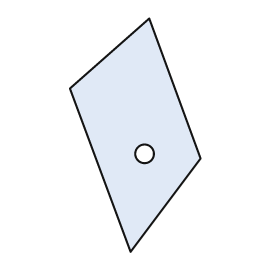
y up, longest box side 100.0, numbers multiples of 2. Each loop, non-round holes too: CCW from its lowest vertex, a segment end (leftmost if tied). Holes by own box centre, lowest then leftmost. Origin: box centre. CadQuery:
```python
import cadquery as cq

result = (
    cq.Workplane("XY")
    .moveTo(-2.0, -50.0)
    .lineTo(28.0, -10.0)
    .lineTo(6.0, 50.0)
    .lineTo(-28.0, 20.0)
    .close()
    .moveTo(4.0, -8.0)
    .circle(4.0)
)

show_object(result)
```